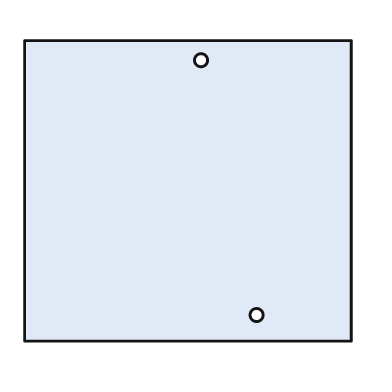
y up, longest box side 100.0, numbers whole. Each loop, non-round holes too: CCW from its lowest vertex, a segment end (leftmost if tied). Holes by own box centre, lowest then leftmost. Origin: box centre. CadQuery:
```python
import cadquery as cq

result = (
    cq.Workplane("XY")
    .moveTo(-50.0, -46.0)
    .lineTo(50.0, -46.0)
    .lineTo(50.0, 46.0)
    .lineTo(-50.0, 46.0)
    .close()
    .moveTo(21.0, -38.0)
    .circle(2.0)
    .moveTo(4.0, 40.0)
    .circle(2.0)
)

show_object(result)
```